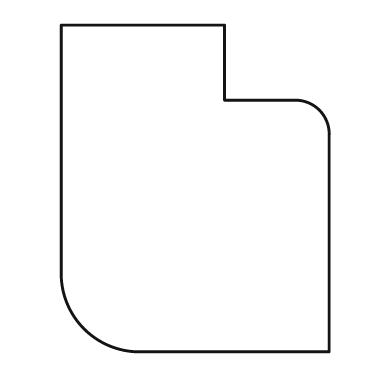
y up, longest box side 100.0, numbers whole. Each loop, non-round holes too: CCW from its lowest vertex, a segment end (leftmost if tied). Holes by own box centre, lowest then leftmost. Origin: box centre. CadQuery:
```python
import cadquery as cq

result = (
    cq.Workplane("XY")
    .moveTo(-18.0, -50.0)
    .lineTo(41.0, -50.0)
    .lineTo(41.0, 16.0)
    .threePointArc((38.0, 24.0), (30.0, 27.0))
    .lineTo(9.0, 27.0)
    .lineTo(9.0, 50.0)
    .lineTo(-41.0, 50.0)
    .lineTo(-41.0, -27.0)
    .threePointArc((-34.0, -43.0), (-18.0, -50.0))
    .close()
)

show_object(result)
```